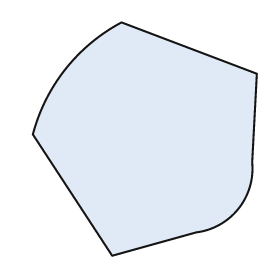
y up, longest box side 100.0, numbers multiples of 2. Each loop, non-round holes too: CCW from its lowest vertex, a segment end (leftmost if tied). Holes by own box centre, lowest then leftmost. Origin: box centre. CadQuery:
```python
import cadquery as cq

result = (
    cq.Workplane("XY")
    .moveTo(-14.0, -50.0)
    .lineTo(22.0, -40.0)
    .threePointArc((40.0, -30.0), (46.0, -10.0))
    .lineTo(48.0, 28.0)
    .lineTo(-10.0, 50.0)
    .threePointArc((-34.0, 30.0), (-48.0, 2.0))
    .close()
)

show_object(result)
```